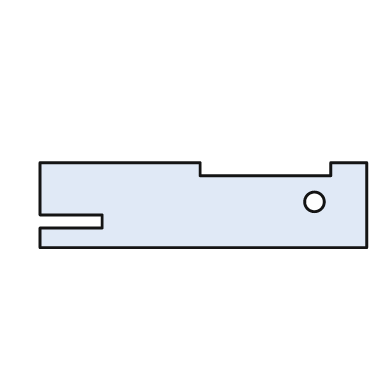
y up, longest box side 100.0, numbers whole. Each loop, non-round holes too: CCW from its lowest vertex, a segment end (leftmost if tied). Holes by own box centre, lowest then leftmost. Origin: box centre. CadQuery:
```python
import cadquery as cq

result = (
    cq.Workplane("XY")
    .moveTo(-50.0, -13.0)
    .lineTo(50.0, -13.0)
    .lineTo(50.0, 13.0)
    .lineTo(39.0, 13.0)
    .lineTo(39.0, 9.0)
    .lineTo(-1.0, 9.0)
    .lineTo(-1.0, 13.0)
    .lineTo(-50.0, 13.0)
    .lineTo(-50.0, -3.0)
    .lineTo(-31.0, -3.0)
    .lineTo(-31.0, -7.0)
    .lineTo(-50.0, -7.0)
    .close()
    .moveTo(34.0, 1.0)
    .circle(3.0)
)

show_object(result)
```